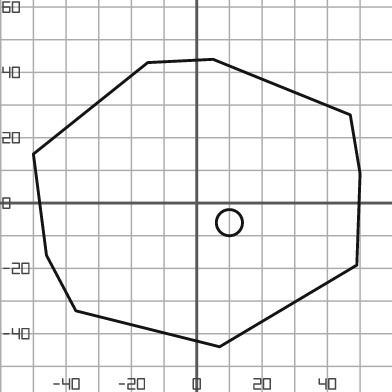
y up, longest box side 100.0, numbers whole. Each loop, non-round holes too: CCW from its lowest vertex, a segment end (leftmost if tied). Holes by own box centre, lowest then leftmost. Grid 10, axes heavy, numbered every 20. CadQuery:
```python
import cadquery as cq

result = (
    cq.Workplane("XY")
    .moveTo(7.0, -44.0)
    .lineTo(49.0, -19.0)
    .lineTo(50.0, 9.0)
    .lineTo(47.0, 27.0)
    .lineTo(5.0, 44.0)
    .lineTo(-15.0, 43.0)
    .lineTo(-50.0, 15.0)
    .lineTo(-46.0, -16.0)
    .lineTo(-37.0, -33.0)
    .close()
    .moveTo(10.0, -6.0)
    .circle(4.0)
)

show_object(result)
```